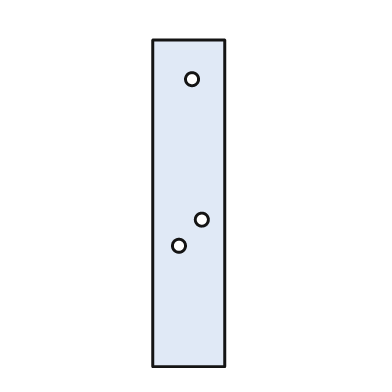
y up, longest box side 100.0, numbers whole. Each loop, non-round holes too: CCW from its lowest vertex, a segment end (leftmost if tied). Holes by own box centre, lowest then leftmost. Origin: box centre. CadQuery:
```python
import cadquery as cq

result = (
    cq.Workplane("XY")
    .moveTo(-11.0, -50.0)
    .lineTo(11.0, -50.0)
    .lineTo(11.0, 50.0)
    .lineTo(-11.0, 50.0)
    .close()
    .moveTo(-3.0, -13.0)
    .circle(2.0)
    .moveTo(4.0, -5.0)
    .circle(2.0)
    .moveTo(1.0, 38.0)
    .circle(2.0)
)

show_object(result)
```